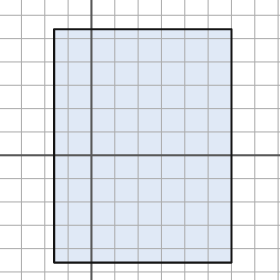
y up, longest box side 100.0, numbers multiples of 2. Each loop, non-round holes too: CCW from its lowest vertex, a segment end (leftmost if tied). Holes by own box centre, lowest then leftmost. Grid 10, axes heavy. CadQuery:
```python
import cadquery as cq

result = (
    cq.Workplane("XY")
    .moveTo(-16.0, -46.0)
    .lineTo(60.0, -46.0)
    .lineTo(60.0, 54.0)
    .lineTo(-16.0, 54.0)
    .close()
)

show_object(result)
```